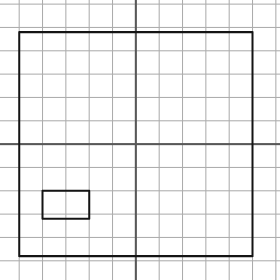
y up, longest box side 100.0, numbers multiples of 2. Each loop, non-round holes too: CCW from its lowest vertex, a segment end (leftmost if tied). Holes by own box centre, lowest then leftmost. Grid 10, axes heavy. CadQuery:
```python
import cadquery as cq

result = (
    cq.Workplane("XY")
    .moveTo(-50.0, -48.0)
    .lineTo(50.0, -48.0)
    .lineTo(50.0, 48.0)
    .lineTo(-50.0, 48.0)
    .close()
    .moveTo(-40.0, -32.0)
    .lineTo(-20.0, -32.0)
    .lineTo(-20.0, -20.0)
    .lineTo(-40.0, -20.0)
    .close()
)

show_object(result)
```